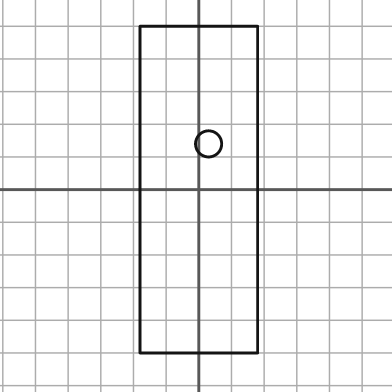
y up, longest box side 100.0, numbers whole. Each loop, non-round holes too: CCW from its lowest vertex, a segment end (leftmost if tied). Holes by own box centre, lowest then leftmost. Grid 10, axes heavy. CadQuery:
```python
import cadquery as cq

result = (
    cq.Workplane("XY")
    .moveTo(-18.0, -50.0)
    .lineTo(18.0, -50.0)
    .lineTo(18.0, 50.0)
    .lineTo(-18.0, 50.0)
    .close()
    .moveTo(3.0, 14.0)
    .circle(4.0)
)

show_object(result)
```